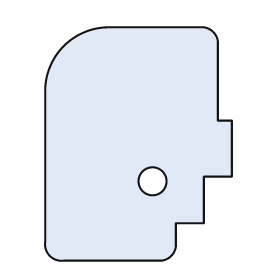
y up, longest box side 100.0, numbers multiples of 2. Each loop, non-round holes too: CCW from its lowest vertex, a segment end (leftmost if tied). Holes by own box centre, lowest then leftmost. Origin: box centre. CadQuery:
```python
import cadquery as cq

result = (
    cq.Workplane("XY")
    .moveTo(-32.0, -50.0)
    .lineTo(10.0, -50.0)
    .threePointArc((14.0, -48.0), (16.0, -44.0))
    .lineTo(16.0, -34.0)
    .lineTo(28.0, -34.0)
    .lineTo(28.0, -14.0)
    .lineTo(40.0, -14.0)
    .lineTo(40.0, 10.0)
    .lineTo(34.0, 10.0)
    .lineTo(34.0, 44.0)
    .threePointArc((32.0, 48.0), (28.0, 50.0))
    .lineTo(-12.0, 50.0)
    .threePointArc((-32.0, 42.0), (-40.0, 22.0))
    .lineTo(-40.0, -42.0)
    .threePointArc((-38.0, -48.0), (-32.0, -50.0))
    .close()
    .moveTo(6.0, -16.0)
    .circle(6.0)
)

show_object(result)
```